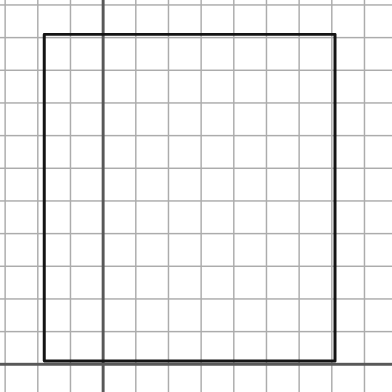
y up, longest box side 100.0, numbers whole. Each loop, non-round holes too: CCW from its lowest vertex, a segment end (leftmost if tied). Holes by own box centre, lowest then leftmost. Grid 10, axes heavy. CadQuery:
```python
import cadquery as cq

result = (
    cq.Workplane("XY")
    .moveTo(-18.0, 1.0)
    .lineTo(71.0, 1.0)
    .lineTo(71.0, 101.0)
    .lineTo(-18.0, 101.0)
    .close()
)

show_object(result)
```